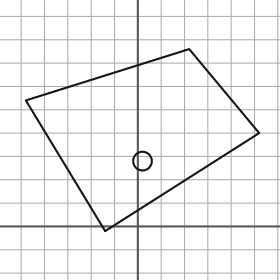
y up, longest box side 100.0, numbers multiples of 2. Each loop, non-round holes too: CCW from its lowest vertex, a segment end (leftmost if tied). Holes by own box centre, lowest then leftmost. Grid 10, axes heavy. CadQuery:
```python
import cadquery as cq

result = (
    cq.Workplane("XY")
    .moveTo(-14.0, -2.0)
    .lineTo(52.0, 40.0)
    .lineTo(22.0, 76.0)
    .lineTo(-48.0, 54.0)
    .close()
    .moveTo(2.0, 28.0)
    .circle(4.0)
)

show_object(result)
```